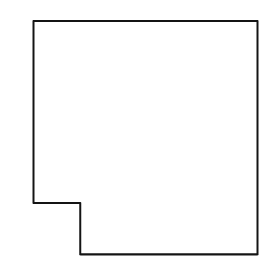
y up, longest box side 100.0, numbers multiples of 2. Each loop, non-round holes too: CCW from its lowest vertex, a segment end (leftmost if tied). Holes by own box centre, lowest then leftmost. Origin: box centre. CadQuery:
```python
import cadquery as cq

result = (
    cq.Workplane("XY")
    .moveTo(-28.0, -50.0)
    .lineTo(48.0, -50.0)
    .lineTo(48.0, 50.0)
    .lineTo(-48.0, 50.0)
    .lineTo(-48.0, -28.0)
    .lineTo(-28.0, -28.0)
    .close()
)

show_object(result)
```